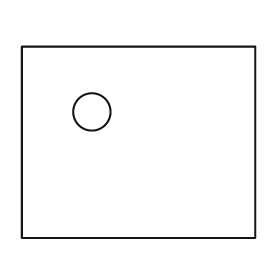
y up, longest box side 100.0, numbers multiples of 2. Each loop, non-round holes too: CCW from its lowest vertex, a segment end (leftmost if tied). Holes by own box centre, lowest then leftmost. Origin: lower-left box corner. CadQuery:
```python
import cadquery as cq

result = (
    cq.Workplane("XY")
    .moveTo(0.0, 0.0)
    .lineTo(100.0, 0.0)
    .lineTo(100.0, 82.0)
    .lineTo(0.0, 82.0)
    .close()
    .moveTo(30.0, 54.0)
    .circle(8.0)
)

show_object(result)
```